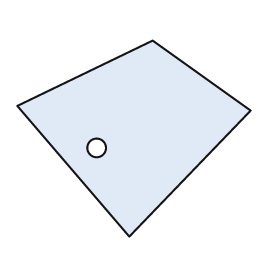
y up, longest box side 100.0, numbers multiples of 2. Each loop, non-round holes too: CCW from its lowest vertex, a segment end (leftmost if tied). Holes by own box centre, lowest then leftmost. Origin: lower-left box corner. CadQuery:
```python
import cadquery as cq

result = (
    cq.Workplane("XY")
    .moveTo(48.0, 0.0)
    .lineTo(100.0, 54.0)
    .lineTo(58.0, 84.0)
    .lineTo(0.0, 56.0)
    .close()
    .moveTo(34.0, 38.0)
    .circle(4.0)
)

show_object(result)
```